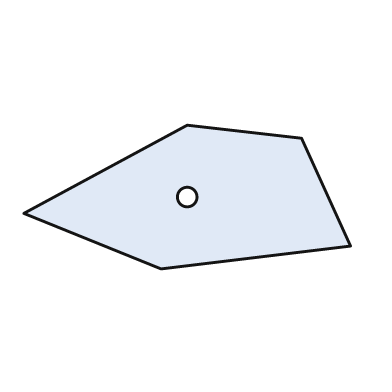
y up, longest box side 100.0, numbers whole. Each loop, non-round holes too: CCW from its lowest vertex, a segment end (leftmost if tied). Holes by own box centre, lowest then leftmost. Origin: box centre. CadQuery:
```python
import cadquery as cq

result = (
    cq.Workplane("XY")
    .moveTo(-8.0, -22.0)
    .lineTo(50.0, -15.0)
    .lineTo(35.0, 18.0)
    .lineTo(0.0, 22.0)
    .lineTo(-50.0, -5.0)
    .close()
    .moveTo(0.0, 0.0)
    .circle(3.0)
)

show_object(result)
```